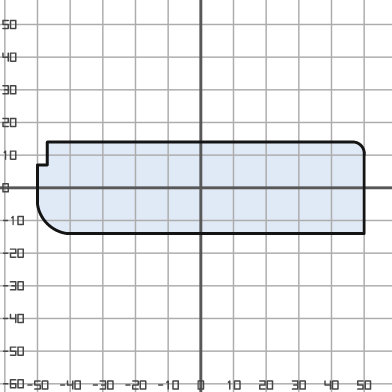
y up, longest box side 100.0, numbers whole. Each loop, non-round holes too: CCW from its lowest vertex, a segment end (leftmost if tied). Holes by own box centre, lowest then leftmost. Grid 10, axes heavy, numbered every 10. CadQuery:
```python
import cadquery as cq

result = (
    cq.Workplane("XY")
    .moveTo(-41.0, -14.0)
    .lineTo(50.0, -14.0)
    .lineTo(50.0, 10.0)
    .threePointArc((49.0, 13.0), (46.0, 14.0))
    .lineTo(-47.0, 14.0)
    .lineTo(-47.0, 7.0)
    .lineTo(-50.0, 7.0)
    .lineTo(-50.0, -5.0)
    .threePointArc((-47.0, -11.0), (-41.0, -14.0))
    .close()
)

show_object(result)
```